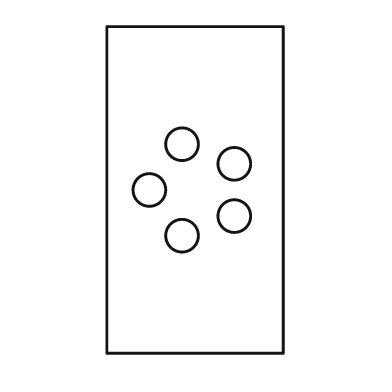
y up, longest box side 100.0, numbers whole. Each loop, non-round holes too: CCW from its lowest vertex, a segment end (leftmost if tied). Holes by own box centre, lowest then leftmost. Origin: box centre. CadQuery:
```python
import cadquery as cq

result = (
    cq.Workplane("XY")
    .moveTo(-27.0, -50.0)
    .lineTo(27.0, -50.0)
    .lineTo(27.0, 50.0)
    .lineTo(-27.0, 50.0)
    .close()
    .moveTo(-4.0, -14.0)
    .circle(5.0)
    .moveTo(12.0, -8.0)
    .circle(5.0)
    .moveTo(-14.0, 0.0)
    .circle(5.0)
    .moveTo(12.0, 8.0)
    .circle(5.0)
    .moveTo(-4.0, 14.0)
    .circle(5.0)
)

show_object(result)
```